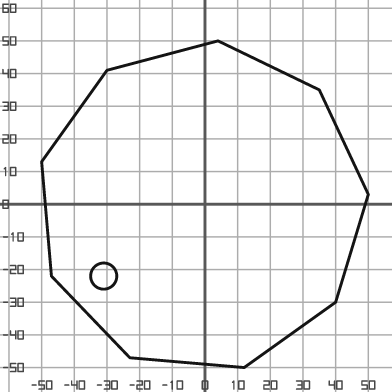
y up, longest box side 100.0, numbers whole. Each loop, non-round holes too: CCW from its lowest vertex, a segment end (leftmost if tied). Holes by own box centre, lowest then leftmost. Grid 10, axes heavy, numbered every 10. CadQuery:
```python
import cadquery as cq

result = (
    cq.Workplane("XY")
    .moveTo(12.0, -50.0)
    .lineTo(40.0, -30.0)
    .lineTo(50.0, 3.0)
    .lineTo(35.0, 35.0)
    .lineTo(4.0, 50.0)
    .lineTo(-30.0, 41.0)
    .lineTo(-50.0, 13.0)
    .lineTo(-47.0, -22.0)
    .lineTo(-23.0, -47.0)
    .close()
    .moveTo(-31.0, -22.0)
    .circle(4.0)
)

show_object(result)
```